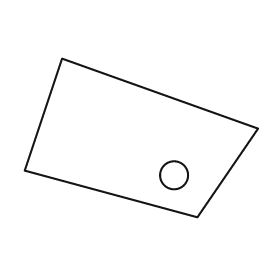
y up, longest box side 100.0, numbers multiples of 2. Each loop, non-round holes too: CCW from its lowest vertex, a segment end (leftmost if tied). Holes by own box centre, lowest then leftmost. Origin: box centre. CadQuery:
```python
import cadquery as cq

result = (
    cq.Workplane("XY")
    .moveTo(24.0, -34.0)
    .lineTo(50.0, 4.0)
    .lineTo(-34.0, 34.0)
    .lineTo(-50.0, -14.0)
    .close()
    .moveTo(14.0, -16.0)
    .circle(6.0)
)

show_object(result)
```